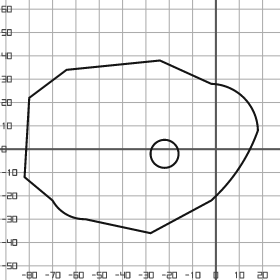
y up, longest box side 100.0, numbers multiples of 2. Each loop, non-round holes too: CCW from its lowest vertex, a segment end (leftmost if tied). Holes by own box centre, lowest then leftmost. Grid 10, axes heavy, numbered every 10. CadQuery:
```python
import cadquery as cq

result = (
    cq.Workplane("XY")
    .moveTo(-28.0, -36.0)
    .lineTo(-2.0, -22.0)
    .threePointArc((10.0, -8.0), (18.0, 8.0))
    .threePointArc((12.0, 22.0), (-2.0, 28.0))
    .lineTo(-24.0, 38.0)
    .lineTo(-64.0, 34.0)
    .lineTo(-80.0, 22.0)
    .lineTo(-82.0, -12.0)
    .lineTo(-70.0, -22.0)
    .threePointArc((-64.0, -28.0), (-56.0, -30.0))
    .close()
    .moveTo(-22.0, -2.0)
    .circle(6.0)
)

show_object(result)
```